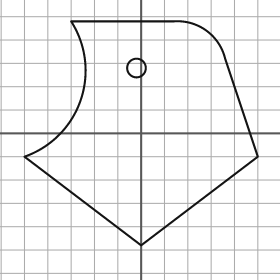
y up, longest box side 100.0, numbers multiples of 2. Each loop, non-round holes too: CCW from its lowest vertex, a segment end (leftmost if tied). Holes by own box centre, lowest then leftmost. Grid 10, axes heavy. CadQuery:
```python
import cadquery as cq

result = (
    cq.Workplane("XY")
    .moveTo(0.0, -48.0)
    .lineTo(50.0, -10.0)
    .lineTo(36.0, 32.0)
    .threePointArc((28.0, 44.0), (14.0, 48.0))
    .lineTo(-30.0, 48.0)
    .threePointArc((-26.0, 14.0), (-50.0, -10.0))
    .close()
    .moveTo(-2.0, 28.0)
    .circle(4.0)
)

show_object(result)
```